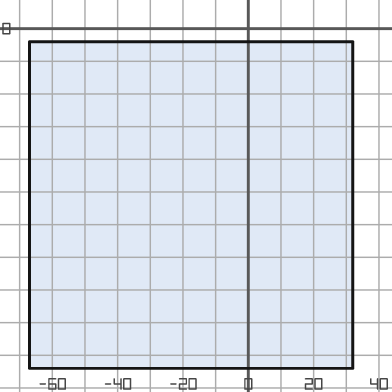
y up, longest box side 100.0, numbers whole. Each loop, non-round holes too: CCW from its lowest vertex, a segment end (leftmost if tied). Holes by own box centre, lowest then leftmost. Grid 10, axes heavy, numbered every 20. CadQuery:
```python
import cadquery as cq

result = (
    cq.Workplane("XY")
    .moveTo(-67.0, -104.0)
    .lineTo(32.0, -104.0)
    .lineTo(32.0, -4.0)
    .lineTo(-67.0, -4.0)
    .close()
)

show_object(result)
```